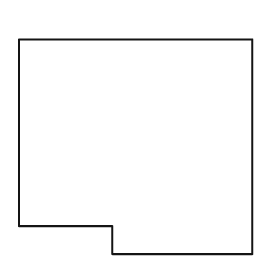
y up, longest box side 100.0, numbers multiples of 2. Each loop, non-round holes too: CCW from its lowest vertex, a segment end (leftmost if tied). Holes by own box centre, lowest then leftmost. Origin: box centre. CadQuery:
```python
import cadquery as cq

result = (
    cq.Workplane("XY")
    .moveTo(-10.0, -46.0)
    .lineTo(50.0, -46.0)
    .lineTo(50.0, 46.0)
    .lineTo(-50.0, 46.0)
    .lineTo(-50.0, -34.0)
    .lineTo(-10.0, -34.0)
    .close()
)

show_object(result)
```